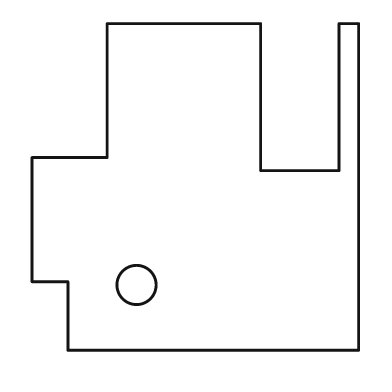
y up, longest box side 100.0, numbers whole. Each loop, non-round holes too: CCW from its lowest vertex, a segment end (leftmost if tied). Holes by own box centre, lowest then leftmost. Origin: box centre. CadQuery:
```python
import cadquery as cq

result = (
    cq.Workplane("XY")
    .moveTo(-39.0, -50.0)
    .lineTo(50.0, -50.0)
    .lineTo(50.0, 50.0)
    .lineTo(44.0, 50.0)
    .lineTo(44.0, 5.0)
    .lineTo(20.0, 5.0)
    .lineTo(20.0, 50.0)
    .lineTo(-27.0, 50.0)
    .lineTo(-27.0, 9.0)
    .lineTo(-50.0, 9.0)
    .lineTo(-50.0, -29.0)
    .lineTo(-39.0, -29.0)
    .close()
    .moveTo(-18.0, -30.0)
    .circle(6.0)
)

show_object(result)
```